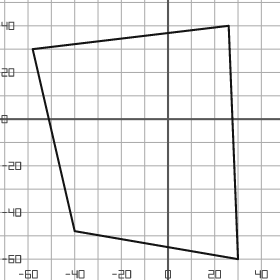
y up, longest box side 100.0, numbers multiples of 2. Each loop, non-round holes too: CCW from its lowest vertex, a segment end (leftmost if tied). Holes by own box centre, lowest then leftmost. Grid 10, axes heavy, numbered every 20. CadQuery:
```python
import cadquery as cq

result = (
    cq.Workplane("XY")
    .moveTo(30.0, -60.0)
    .lineTo(26.0, 40.0)
    .lineTo(-58.0, 30.0)
    .lineTo(-40.0, -48.0)
    .close()
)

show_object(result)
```